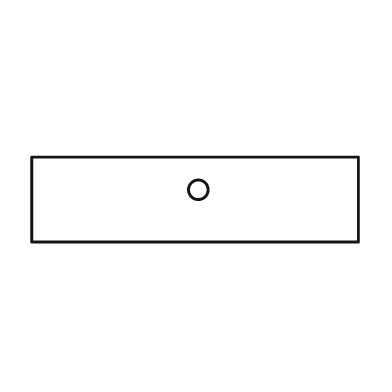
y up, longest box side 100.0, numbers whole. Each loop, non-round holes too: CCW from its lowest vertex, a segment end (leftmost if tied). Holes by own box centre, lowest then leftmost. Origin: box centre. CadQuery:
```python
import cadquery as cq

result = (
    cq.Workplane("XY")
    .moveTo(-50.0, -13.0)
    .lineTo(50.0, -13.0)
    .lineTo(50.0, 13.0)
    .lineTo(-50.0, 13.0)
    .close()
    .moveTo(1.0, 3.0)
    .circle(3.0)
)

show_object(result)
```